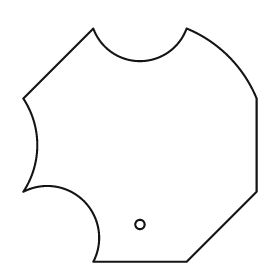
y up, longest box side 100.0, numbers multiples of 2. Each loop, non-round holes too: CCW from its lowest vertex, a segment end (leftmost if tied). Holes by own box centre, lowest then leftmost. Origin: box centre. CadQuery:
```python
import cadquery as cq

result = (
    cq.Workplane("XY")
    .moveTo(-20.0, -50.0)
    .lineTo(20.0, -50.0)
    .lineTo(50.0, -20.0)
    .lineTo(50.0, 20.0)
    .threePointArc((38.0, 38.0), (20.0, 50.0))
    .threePointArc((0.0, 36.0), (-20.0, 50.0))
    .lineTo(-50.0, 20.0)
    .threePointArc((-44.0, 0.0), (-50.0, -20.0))
    .threePointArc((-24.0, -24.0), (-20.0, -50.0))
    .close()
    .moveTo(0.0, -34.0)
    .circle(2.0)
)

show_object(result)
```